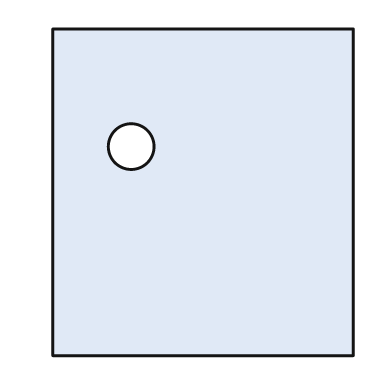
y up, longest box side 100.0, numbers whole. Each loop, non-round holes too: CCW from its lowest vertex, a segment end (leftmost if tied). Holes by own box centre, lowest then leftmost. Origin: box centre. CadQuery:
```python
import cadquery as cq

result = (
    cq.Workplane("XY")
    .moveTo(-46.0, -50.0)
    .lineTo(46.0, -50.0)
    .lineTo(46.0, 50.0)
    .lineTo(-46.0, 50.0)
    .close()
    .moveTo(-22.0, 14.0)
    .circle(7.0)
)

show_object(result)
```